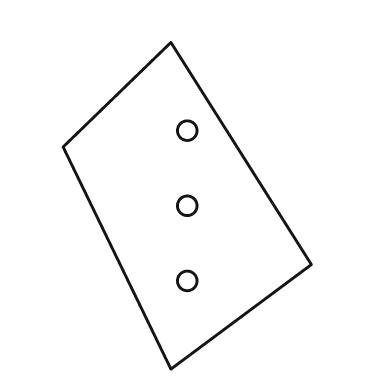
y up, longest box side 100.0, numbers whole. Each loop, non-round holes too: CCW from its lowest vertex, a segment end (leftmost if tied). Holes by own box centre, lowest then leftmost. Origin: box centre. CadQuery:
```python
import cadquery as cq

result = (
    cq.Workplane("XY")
    .moveTo(-5.0, -50.0)
    .lineTo(38.0, -18.0)
    .lineTo(-5.0, 50.0)
    .lineTo(-38.0, 18.0)
    .close()
    .moveTo(0.0, -23.0)
    .circle(3.0)
    .moveTo(0.0, 0.0)
    .circle(3.0)
    .moveTo(0.0, 23.0)
    .circle(3.0)
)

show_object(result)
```